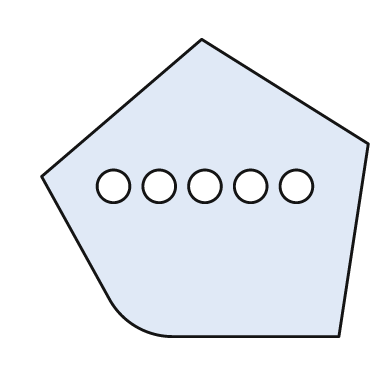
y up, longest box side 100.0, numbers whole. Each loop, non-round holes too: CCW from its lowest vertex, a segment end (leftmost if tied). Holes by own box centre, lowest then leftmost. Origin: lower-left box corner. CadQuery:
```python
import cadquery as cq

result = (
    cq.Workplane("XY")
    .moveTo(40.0, 0.0)
    .lineTo(91.0, 0.0)
    .lineTo(100.0, 59.0)
    .lineTo(49.0, 91.0)
    .lineTo(0.0, 49.0)
    .lineTo(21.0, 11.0)
    .threePointArc((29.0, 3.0), (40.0, 0.0))
    .close()
    .moveTo(22.0, 46.0)
    .circle(5.0)
    .moveTo(36.0, 46.0)
    .circle(5.0)
    .moveTo(50.0, 46.0)
    .circle(5.0)
    .moveTo(64.0, 46.0)
    .circle(5.0)
    .moveTo(78.0, 46.0)
    .circle(5.0)
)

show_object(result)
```